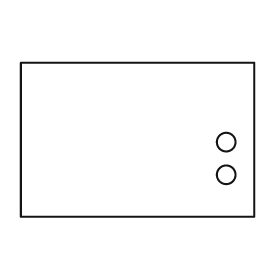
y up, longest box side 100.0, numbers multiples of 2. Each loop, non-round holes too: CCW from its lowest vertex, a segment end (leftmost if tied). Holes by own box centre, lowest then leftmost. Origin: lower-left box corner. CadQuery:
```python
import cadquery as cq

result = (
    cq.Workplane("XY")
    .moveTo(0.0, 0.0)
    .lineTo(100.0, 0.0)
    .lineTo(100.0, 66.0)
    .lineTo(0.0, 66.0)
    .close()
    .moveTo(88.0, 18.0)
    .circle(4.0)
    .moveTo(88.0, 32.0)
    .circle(4.0)
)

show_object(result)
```